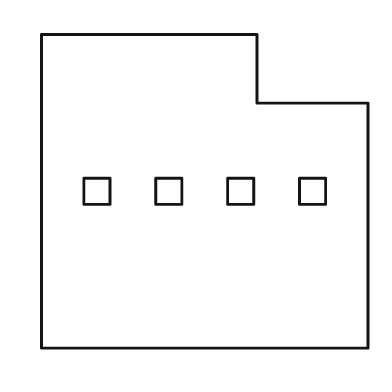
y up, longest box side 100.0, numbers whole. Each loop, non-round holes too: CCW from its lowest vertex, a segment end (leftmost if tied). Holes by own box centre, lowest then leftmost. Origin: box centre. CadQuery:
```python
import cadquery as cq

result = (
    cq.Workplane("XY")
    .moveTo(-50.0, -48.0)
    .lineTo(50.0, -48.0)
    .lineTo(50.0, 27.0)
    .lineTo(16.0, 27.0)
    .lineTo(16.0, 48.0)
    .lineTo(-50.0, 48.0)
    .close()
    .moveTo(-37.0, -4.0)
    .lineTo(-29.0, -4.0)
    .lineTo(-29.0, 4.0)
    .lineTo(-37.0, 4.0)
    .close()
    .moveTo(-15.0, -4.0)
    .lineTo(-7.0, -4.0)
    .lineTo(-7.0, 4.0)
    .lineTo(-15.0, 4.0)
    .close()
    .moveTo(7.0, -4.0)
    .lineTo(15.0, -4.0)
    .lineTo(15.0, 4.0)
    .lineTo(7.0, 4.0)
    .close()
    .moveTo(29.0, -4.0)
    .lineTo(37.0, -4.0)
    .lineTo(37.0, 4.0)
    .lineTo(29.0, 4.0)
    .close()
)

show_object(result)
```